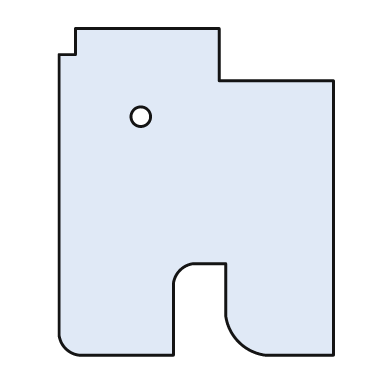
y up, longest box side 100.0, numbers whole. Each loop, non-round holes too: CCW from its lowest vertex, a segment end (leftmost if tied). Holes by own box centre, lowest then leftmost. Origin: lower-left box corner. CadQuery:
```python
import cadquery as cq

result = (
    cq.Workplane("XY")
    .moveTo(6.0, 0.0)
    .lineTo(35.0, 0.0)
    .lineTo(35.0, 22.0)
    .threePointArc((37.0, 26.0), (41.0, 28.0))
    .lineTo(51.0, 28.0)
    .lineTo(51.0, 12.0)
    .threePointArc((55.0, 4.0), (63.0, 0.0))
    .lineTo(84.0, 0.0)
    .lineTo(84.0, 84.0)
    .lineTo(49.0, 84.0)
    .lineTo(49.0, 100.0)
    .lineTo(5.0, 100.0)
    .lineTo(5.0, 92.0)
    .lineTo(0.0, 92.0)
    .lineTo(0.0, 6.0)
    .threePointArc((2.0, 2.0), (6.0, 0.0))
    .close()
    .moveTo(25.0, 73.0)
    .circle(3.0)
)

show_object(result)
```